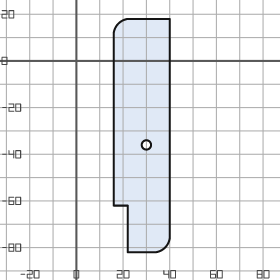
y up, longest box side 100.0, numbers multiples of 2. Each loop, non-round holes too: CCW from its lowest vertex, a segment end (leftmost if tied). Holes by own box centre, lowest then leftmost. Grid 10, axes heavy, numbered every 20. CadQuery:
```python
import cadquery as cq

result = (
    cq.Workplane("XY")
    .moveTo(22.0, -82.0)
    .lineTo(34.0, -82.0)
    .threePointArc((38.0, -80.0), (40.0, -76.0))
    .lineTo(40.0, 18.0)
    .lineTo(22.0, 18.0)
    .threePointArc((18.0, 16.0), (16.0, 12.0))
    .lineTo(16.0, -62.0)
    .lineTo(22.0, -62.0)
    .close()
    .moveTo(30.0, -36.0)
    .circle(2.0)
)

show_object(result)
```